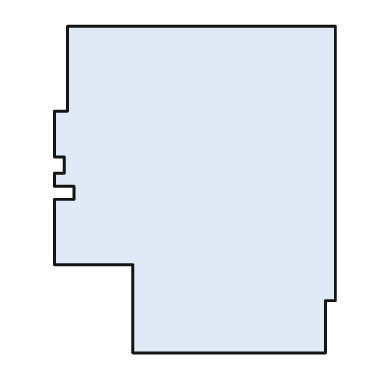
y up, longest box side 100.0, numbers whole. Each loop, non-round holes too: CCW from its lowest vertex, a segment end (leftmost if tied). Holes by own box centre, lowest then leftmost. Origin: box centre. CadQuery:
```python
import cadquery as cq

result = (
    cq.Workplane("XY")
    .moveTo(-19.0, -50.0)
    .lineTo(40.0, -50.0)
    .lineTo(40.0, -34.0)
    .lineTo(43.0, -34.0)
    .lineTo(43.0, 50.0)
    .lineTo(-39.0, 50.0)
    .lineTo(-39.0, 24.0)
    .lineTo(-43.0, 24.0)
    .lineTo(-43.0, 10.0)
    .lineTo(-40.0, 10.0)
    .lineTo(-40.0, 5.0)
    .lineTo(-43.0, 5.0)
    .lineTo(-43.0, 1.0)
    .lineTo(-37.0, 1.0)
    .lineTo(-37.0, -3.0)
    .lineTo(-43.0, -3.0)
    .lineTo(-43.0, -23.0)
    .lineTo(-19.0, -23.0)
    .close()
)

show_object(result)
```